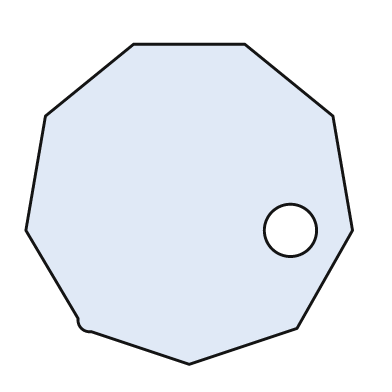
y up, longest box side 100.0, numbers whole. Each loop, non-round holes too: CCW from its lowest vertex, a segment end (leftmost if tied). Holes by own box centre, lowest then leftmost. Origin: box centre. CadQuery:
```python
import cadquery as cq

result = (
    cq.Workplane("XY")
    .moveTo(0.0, -49.0)
    .lineTo(33.0, -38.0)
    .lineTo(50.0, -8.0)
    .lineTo(44.0, 27.0)
    .lineTo(17.0, 49.0)
    .lineTo(-17.0, 49.0)
    .lineTo(-44.0, 27.0)
    .lineTo(-50.0, -8.0)
    .lineTo(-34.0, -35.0)
    .threePointArc((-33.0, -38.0), (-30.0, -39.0))
    .close()
    .moveTo(31.0, -8.0)
    .circle(8.0)
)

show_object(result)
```